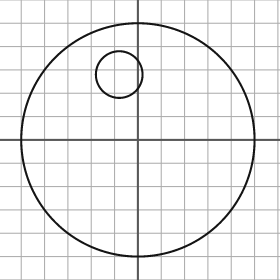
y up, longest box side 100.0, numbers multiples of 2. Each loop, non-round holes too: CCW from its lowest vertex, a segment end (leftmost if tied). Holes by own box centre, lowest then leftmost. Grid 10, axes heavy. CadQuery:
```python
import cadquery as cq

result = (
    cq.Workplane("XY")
    .moveTo(0.0, 0.0)
    .circle(50.0)
    .moveTo(-8.0, 28.0)
    .circle(10.0)
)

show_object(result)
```